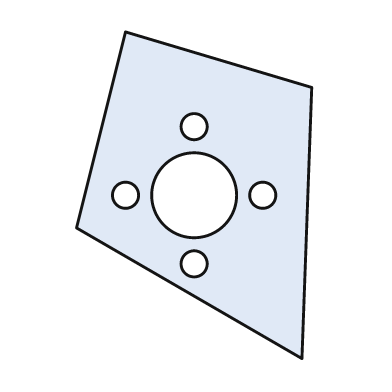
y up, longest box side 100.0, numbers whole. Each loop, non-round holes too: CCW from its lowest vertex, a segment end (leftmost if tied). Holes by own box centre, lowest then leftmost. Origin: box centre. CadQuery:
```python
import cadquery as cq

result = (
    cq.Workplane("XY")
    .moveTo(33.0, -50.0)
    .lineTo(36.0, 33.0)
    .lineTo(-21.0, 50.0)
    .lineTo(-36.0, -10.0)
    .close()
    .moveTo(0.0, -21.0)
    .circle(4.0)
    .moveTo(-21.0, 0.0)
    .circle(4.0)
    .moveTo(0.0, 0.0)
    .circle(13.0)
    .moveTo(21.0, 0.0)
    .circle(4.0)
    .moveTo(0.0, 21.0)
    .circle(4.0)
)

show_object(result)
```